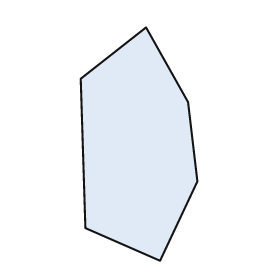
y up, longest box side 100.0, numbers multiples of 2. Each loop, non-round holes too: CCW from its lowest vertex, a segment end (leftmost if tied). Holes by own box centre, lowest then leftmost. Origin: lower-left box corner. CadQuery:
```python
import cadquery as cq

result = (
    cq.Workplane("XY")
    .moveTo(34.0, 0.0)
    .lineTo(50.0, 34.0)
    .lineTo(46.0, 68.0)
    .lineTo(28.0, 100.0)
    .lineTo(0.0, 78.0)
    .lineTo(2.0, 14.0)
    .close()
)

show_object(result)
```